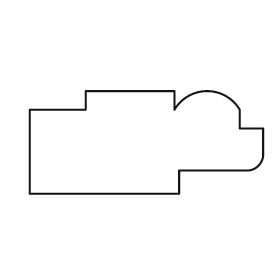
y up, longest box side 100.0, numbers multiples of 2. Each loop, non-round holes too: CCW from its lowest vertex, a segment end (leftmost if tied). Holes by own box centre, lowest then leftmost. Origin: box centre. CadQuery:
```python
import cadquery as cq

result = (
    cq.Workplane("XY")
    .moveTo(-50.0, -22.0)
    .lineTo(14.0, -22.0)
    .lineTo(14.0, -12.0)
    .lineTo(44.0, -12.0)
    .threePointArc((48.0, -10.0), (50.0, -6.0))
    .lineTo(50.0, 6.0)
    .lineTo(40.0, 6.0)
    .lineTo(40.0, 14.0)
    .threePointArc((26.0, 22.0), (12.0, 14.0))
    .lineTo(12.0, 22.0)
    .lineTo(-26.0, 22.0)
    .lineTo(-26.0, 14.0)
    .lineTo(-50.0, 14.0)
    .close()
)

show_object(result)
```